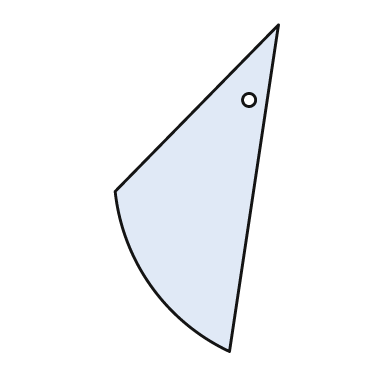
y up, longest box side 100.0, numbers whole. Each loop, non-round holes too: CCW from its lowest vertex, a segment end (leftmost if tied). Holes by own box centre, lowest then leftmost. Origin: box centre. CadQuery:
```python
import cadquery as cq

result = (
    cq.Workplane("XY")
    .moveTo(10.0, -50.0)
    .lineTo(25.0, 50.0)
    .lineTo(-25.0, -1.0)
    .threePointArc((-14.0, -30.0), (10.0, -50.0))
    .close()
    .moveTo(16.0, 27.0)
    .circle(2.0)
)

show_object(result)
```